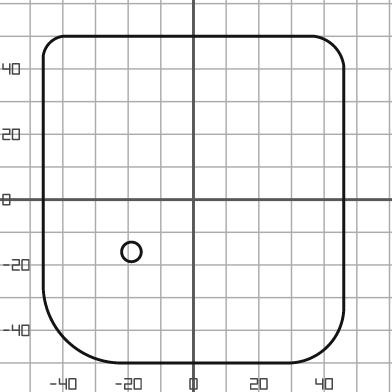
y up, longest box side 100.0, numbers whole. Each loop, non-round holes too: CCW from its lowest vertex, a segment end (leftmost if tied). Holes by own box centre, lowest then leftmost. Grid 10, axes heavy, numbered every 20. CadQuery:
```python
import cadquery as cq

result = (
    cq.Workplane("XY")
    .moveTo(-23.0, -50.0)
    .lineTo(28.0, -50.0)
    .threePointArc((41.0, -45.0), (46.0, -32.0))
    .lineTo(46.0, 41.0)
    .threePointArc((43.0, 47.0), (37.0, 50.0))
    .lineTo(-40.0, 50.0)
    .threePointArc((-44.0, 48.0), (-46.0, 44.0))
    .lineTo(-46.0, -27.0)
    .threePointArc((-39.0, -43.0), (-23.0, -50.0))
    .close()
    .moveTo(-19.0, -16.0)
    .circle(3.0)
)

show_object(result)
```